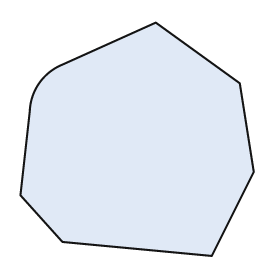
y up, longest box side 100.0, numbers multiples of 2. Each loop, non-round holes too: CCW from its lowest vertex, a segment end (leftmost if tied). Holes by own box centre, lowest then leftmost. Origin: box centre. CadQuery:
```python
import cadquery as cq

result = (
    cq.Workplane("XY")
    .moveTo(32.0, -50.0)
    .lineTo(50.0, -14.0)
    .lineTo(44.0, 24.0)
    .lineTo(8.0, 50.0)
    .lineTo(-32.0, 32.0)
    .threePointArc((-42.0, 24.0), (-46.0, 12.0))
    .lineTo(-50.0, -24.0)
    .lineTo(-32.0, -44.0)
    .close()
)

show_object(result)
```